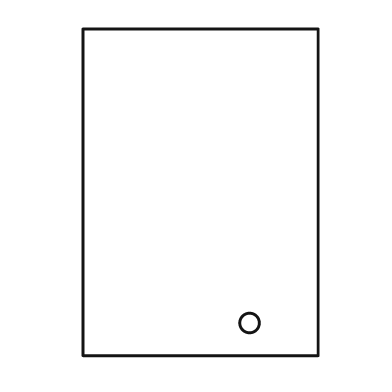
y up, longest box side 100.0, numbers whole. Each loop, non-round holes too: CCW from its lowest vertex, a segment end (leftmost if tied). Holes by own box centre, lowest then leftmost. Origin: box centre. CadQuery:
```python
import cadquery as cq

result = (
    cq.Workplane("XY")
    .moveTo(-36.0, -50.0)
    .lineTo(36.0, -50.0)
    .lineTo(36.0, 50.0)
    .lineTo(-36.0, 50.0)
    .close()
    .moveTo(15.0, -40.0)
    .circle(3.0)
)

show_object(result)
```